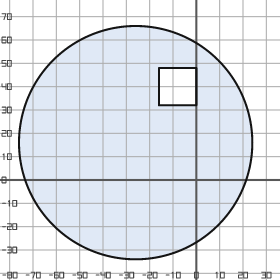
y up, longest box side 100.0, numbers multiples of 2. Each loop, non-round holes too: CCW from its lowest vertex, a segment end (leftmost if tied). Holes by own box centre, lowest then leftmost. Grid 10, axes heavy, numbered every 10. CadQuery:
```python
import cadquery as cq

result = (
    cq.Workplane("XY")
    .moveTo(-26.0, 16.0)
    .circle(50.0)
    .moveTo(-16.0, 32.0)
    .lineTo(0.0, 32.0)
    .lineTo(0.0, 48.0)
    .lineTo(-16.0, 48.0)
    .close()
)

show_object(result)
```